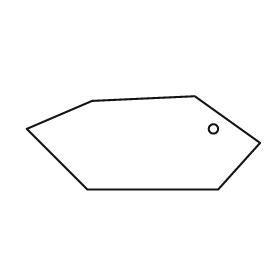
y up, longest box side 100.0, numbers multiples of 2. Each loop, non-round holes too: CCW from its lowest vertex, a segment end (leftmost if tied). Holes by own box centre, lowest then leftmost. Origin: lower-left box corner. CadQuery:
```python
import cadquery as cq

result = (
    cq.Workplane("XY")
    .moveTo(26.0, 0.0)
    .lineTo(82.0, 0.0)
    .lineTo(100.0, 20.0)
    .lineTo(72.0, 40.0)
    .lineTo(28.0, 38.0)
    .lineTo(0.0, 26.0)
    .close()
    .moveTo(80.0, 26.0)
    .circle(2.0)
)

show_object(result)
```